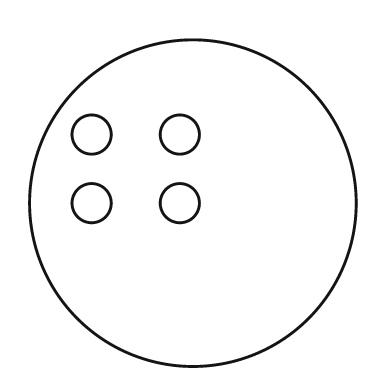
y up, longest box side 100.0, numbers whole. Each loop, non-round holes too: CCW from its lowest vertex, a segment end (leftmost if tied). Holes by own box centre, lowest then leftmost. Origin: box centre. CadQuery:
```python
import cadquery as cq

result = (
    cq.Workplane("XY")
    .moveTo(0.0, 0.0)
    .circle(50.0)
    .moveTo(-31.0, 0.0)
    .circle(6.0)
    .moveTo(-4.0, 0.0)
    .circle(6.0)
    .moveTo(-31.0, 21.0)
    .circle(6.0)
    .moveTo(-4.0, 21.0)
    .circle(6.0)
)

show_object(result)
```